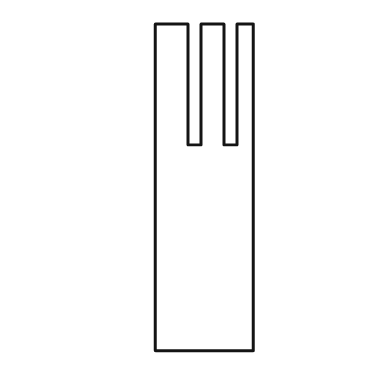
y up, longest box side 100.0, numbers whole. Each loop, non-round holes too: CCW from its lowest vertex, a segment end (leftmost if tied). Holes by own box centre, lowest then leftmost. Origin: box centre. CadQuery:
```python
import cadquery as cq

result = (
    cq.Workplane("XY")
    .moveTo(-15.0, -50.0)
    .lineTo(15.0, -50.0)
    .lineTo(15.0, 50.0)
    .lineTo(10.0, 50.0)
    .lineTo(10.0, 13.0)
    .lineTo(6.0, 13.0)
    .lineTo(6.0, 50.0)
    .lineTo(-1.0, 50.0)
    .lineTo(-1.0, 13.0)
    .lineTo(-5.0, 13.0)
    .lineTo(-5.0, 50.0)
    .lineTo(-15.0, 50.0)
    .close()
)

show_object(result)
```